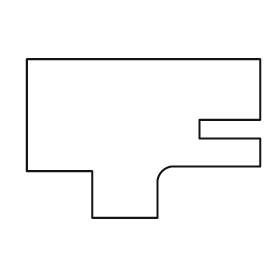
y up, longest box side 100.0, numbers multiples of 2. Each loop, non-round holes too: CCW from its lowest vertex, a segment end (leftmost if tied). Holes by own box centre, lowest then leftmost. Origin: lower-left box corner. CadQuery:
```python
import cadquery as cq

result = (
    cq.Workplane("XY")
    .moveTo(28.0, 0.0)
    .lineTo(56.0, 0.0)
    .lineTo(56.0, 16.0)
    .threePointArc((58.0, 20.0), (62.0, 22.0))
    .lineTo(100.0, 22.0)
    .lineTo(100.0, 34.0)
    .lineTo(74.0, 34.0)
    .lineTo(74.0, 42.0)
    .lineTo(100.0, 42.0)
    .lineTo(100.0, 68.0)
    .lineTo(0.0, 68.0)
    .lineTo(0.0, 20.0)
    .lineTo(28.0, 20.0)
    .close()
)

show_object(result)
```